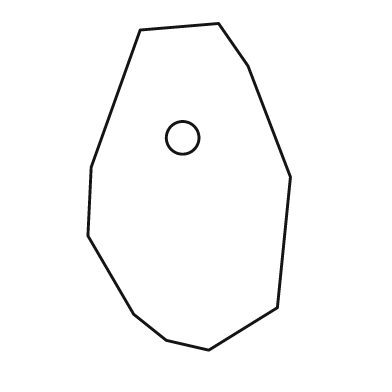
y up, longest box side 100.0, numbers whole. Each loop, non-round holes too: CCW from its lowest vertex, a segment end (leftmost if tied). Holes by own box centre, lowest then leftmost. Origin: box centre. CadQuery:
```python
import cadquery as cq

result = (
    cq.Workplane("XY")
    .moveTo(6.0, -50.0)
    .lineTo(27.0, -37.0)
    .lineTo(31.0, 3.0)
    .lineTo(18.0, 37.0)
    .lineTo(9.0, 50.0)
    .lineTo(-15.0, 48.0)
    .lineTo(-30.0, 6.0)
    .lineTo(-31.0, -15.0)
    .lineTo(-17.0, -39.0)
    .lineTo(-7.0, -47.0)
    .close()
    .moveTo(-2.0, 15.0)
    .circle(5.0)
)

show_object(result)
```